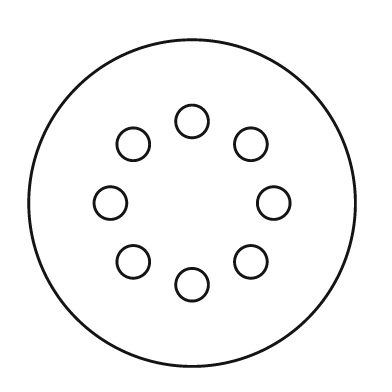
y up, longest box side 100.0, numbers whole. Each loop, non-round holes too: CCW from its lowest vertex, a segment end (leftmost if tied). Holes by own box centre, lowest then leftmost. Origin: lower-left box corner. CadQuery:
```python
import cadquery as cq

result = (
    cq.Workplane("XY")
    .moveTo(50.0, 50.0)
    .circle(50.0)
    .moveTo(50.0, 25.0)
    .circle(5.0)
    .moveTo(32.0, 32.0)
    .circle(5.0)
    .moveTo(68.0, 32.0)
    .circle(5.0)
    .moveTo(25.0, 50.0)
    .circle(5.0)
    .moveTo(75.0, 50.0)
    .circle(5.0)
    .moveTo(32.0, 68.0)
    .circle(5.0)
    .moveTo(68.0, 68.0)
    .circle(5.0)
    .moveTo(50.0, 75.0)
    .circle(5.0)
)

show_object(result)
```